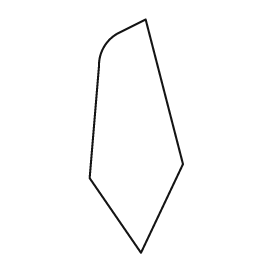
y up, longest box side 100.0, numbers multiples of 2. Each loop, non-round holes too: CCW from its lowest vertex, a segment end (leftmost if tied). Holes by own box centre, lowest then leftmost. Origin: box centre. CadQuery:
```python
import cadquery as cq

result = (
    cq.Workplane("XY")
    .moveTo(2.0, -50.0)
    .lineTo(20.0, -12.0)
    .lineTo(4.0, 50.0)
    .lineTo(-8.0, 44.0)
    .threePointArc((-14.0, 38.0), (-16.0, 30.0))
    .lineTo(-20.0, -18.0)
    .close()
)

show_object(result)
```